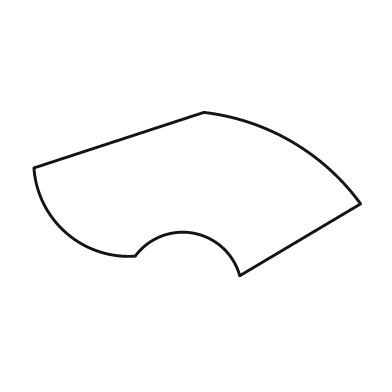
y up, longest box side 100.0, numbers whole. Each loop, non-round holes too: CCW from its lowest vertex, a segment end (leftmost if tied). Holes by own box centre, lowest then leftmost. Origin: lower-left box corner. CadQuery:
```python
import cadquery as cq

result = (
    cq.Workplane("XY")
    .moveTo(63.0, 0.0)
    .lineTo(100.0, 22.0)
    .threePointArc((79.0, 41.0), (52.0, 50.0))
    .lineTo(0.0, 33.0)
    .threePointArc((10.0, 13.0), (31.0, 6.0))
    .threePointArc((49.0, 13.0), (63.0, 0.0))
    .close()
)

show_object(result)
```